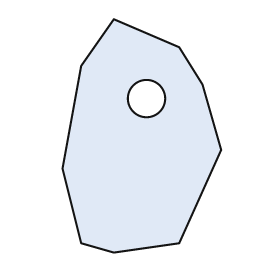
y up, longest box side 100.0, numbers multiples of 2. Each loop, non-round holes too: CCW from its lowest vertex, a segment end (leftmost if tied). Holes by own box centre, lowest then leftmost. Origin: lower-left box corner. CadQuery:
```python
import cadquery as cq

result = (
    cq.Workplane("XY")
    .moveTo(22.0, 0.0)
    .lineTo(50.0, 4.0)
    .lineTo(68.0, 44.0)
    .lineTo(60.0, 72.0)
    .lineTo(50.0, 88.0)
    .lineTo(22.0, 100.0)
    .lineTo(8.0, 80.0)
    .lineTo(0.0, 36.0)
    .lineTo(8.0, 4.0)
    .close()
    .moveTo(36.0, 66.0)
    .circle(8.0)
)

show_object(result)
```